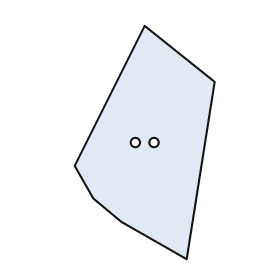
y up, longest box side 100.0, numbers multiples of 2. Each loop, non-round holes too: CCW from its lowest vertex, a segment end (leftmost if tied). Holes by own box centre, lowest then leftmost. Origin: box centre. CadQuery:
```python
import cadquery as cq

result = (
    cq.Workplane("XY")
    .moveTo(18.0, -50.0)
    .lineTo(30.0, 26.0)
    .lineTo(0.0, 50.0)
    .lineTo(-30.0, -10.0)
    .lineTo(-22.0, -24.0)
    .lineTo(-10.0, -34.0)
    .close()
    .moveTo(-4.0, 0.0)
    .circle(2.0)
    .moveTo(4.0, 0.0)
    .circle(2.0)
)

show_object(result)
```